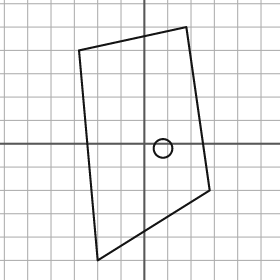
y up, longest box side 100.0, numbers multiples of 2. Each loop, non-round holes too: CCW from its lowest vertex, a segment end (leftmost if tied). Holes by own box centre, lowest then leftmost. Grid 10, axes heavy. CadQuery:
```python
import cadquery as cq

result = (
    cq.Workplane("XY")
    .moveTo(-20.0, -50.0)
    .lineTo(28.0, -20.0)
    .lineTo(18.0, 50.0)
    .lineTo(-28.0, 40.0)
    .close()
    .moveTo(8.0, -2.0)
    .circle(4.0)
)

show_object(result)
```